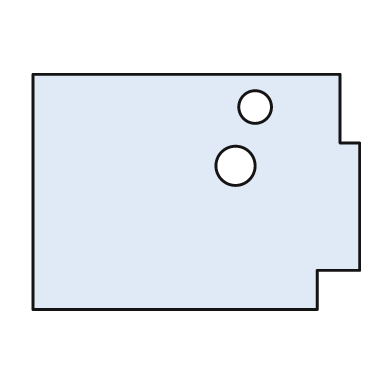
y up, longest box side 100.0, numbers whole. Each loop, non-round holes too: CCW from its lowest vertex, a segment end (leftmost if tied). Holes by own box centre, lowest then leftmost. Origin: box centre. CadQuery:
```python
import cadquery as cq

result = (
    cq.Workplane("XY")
    .moveTo(-50.0, -36.0)
    .lineTo(37.0, -36.0)
    .lineTo(37.0, -24.0)
    .lineTo(50.0, -24.0)
    .lineTo(50.0, 15.0)
    .lineTo(44.0, 15.0)
    .lineTo(44.0, 36.0)
    .lineTo(-50.0, 36.0)
    .close()
    .moveTo(12.0, 8.0)
    .circle(6.0)
    .moveTo(18.0, 26.0)
    .circle(5.0)
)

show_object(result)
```